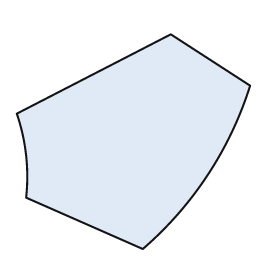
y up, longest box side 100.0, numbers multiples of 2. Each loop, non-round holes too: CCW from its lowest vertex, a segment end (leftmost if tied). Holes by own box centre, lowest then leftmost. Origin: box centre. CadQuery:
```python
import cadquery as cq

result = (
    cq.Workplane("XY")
    .moveTo(4.0, -46.0)
    .threePointArc((32.0, -14.0), (50.0, 24.0))
    .lineTo(16.0, 46.0)
    .lineTo(-50.0, 12.0)
    .threePointArc((-46.0, -6.0), (-46.0, -24.0))
    .close()
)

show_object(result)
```